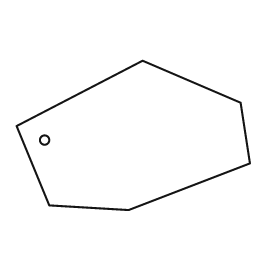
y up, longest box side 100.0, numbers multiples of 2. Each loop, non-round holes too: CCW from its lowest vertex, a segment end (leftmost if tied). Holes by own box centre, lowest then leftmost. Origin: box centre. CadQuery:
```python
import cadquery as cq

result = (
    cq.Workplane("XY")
    .moveTo(-2.0, -32.0)
    .lineTo(50.0, -12.0)
    .lineTo(46.0, 14.0)
    .lineTo(4.0, 32.0)
    .lineTo(-50.0, 4.0)
    .lineTo(-36.0, -30.0)
    .close()
    .moveTo(-38.0, -2.0)
    .circle(2.0)
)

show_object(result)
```